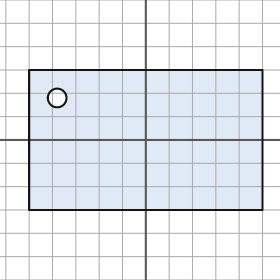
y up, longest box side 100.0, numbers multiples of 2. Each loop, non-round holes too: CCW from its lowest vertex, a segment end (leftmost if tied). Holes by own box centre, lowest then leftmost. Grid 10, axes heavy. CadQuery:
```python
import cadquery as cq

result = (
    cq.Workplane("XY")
    .moveTo(-50.0, -30.0)
    .lineTo(50.0, -30.0)
    .lineTo(50.0, 30.0)
    .lineTo(-50.0, 30.0)
    .close()
    .moveTo(-38.0, 18.0)
    .circle(4.0)
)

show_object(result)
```